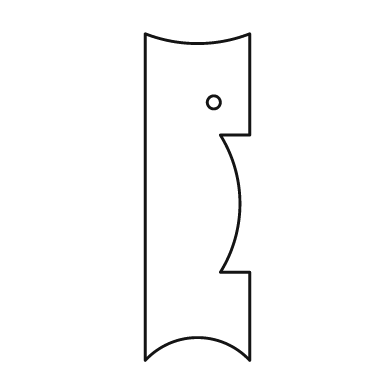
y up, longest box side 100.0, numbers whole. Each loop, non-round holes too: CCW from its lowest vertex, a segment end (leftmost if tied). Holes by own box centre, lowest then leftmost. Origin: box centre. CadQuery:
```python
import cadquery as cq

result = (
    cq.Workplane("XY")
    .moveTo(-16.0, -50.0)
    .threePointArc((0.0, -43.0), (16.0, -50.0))
    .lineTo(16.0, -23.0)
    .lineTo(7.0, -23.0)
    .threePointArc((13.0, -2.0), (7.0, 19.0))
    .lineTo(16.0, 19.0)
    .lineTo(16.0, 50.0)
    .threePointArc((0.0, 47.0), (-16.0, 50.0))
    .close()
    .moveTo(5.0, 29.0)
    .circle(2.0)
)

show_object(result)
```